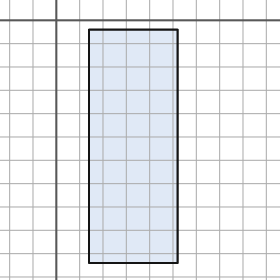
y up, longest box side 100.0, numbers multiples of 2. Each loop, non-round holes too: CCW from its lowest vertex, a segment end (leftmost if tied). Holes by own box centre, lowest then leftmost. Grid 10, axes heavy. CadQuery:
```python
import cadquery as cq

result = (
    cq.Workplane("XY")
    .moveTo(14.0, -104.0)
    .lineTo(52.0, -104.0)
    .lineTo(52.0, -4.0)
    .lineTo(14.0, -4.0)
    .close()
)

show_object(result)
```